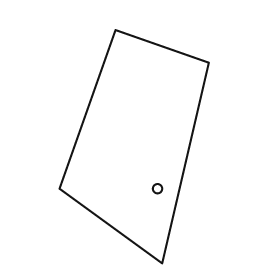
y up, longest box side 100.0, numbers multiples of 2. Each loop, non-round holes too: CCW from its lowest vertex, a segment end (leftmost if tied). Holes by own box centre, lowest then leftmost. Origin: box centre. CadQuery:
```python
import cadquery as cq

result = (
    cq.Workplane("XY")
    .moveTo(12.0, -50.0)
    .lineTo(32.0, 36.0)
    .lineTo(-8.0, 50.0)
    .lineTo(-32.0, -18.0)
    .close()
    .moveTo(10.0, -18.0)
    .circle(2.0)
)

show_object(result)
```